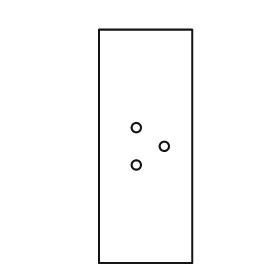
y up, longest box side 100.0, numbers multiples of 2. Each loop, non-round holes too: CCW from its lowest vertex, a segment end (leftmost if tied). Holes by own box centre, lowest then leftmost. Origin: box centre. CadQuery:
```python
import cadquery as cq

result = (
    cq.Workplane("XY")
    .moveTo(-20.0, -50.0)
    .lineTo(20.0, -50.0)
    .lineTo(20.0, 50.0)
    .lineTo(-20.0, 50.0)
    .close()
    .moveTo(-4.0, -8.0)
    .circle(2.0)
    .moveTo(8.0, 0.0)
    .circle(2.0)
    .moveTo(-4.0, 8.0)
    .circle(2.0)
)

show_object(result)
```